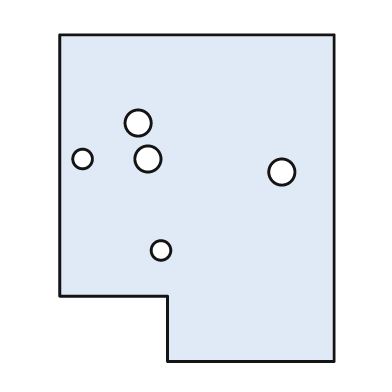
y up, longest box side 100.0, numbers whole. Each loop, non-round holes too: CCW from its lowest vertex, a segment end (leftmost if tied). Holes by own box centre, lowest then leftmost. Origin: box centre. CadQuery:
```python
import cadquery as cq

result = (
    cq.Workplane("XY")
    .moveTo(-9.0, -50.0)
    .lineTo(42.0, -50.0)
    .lineTo(42.0, 50.0)
    .lineTo(-42.0, 50.0)
    .lineTo(-42.0, -30.0)
    .lineTo(-9.0, -30.0)
    .close()
    .moveTo(-11.0, -16.0)
    .circle(3.0)
    .moveTo(26.0, 8.0)
    .circle(4.0)
    .moveTo(-35.0, 12.0)
    .circle(3.0)
    .moveTo(-15.0, 12.0)
    .circle(4.0)
    .moveTo(-18.0, 23.0)
    .circle(4.0)
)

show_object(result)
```